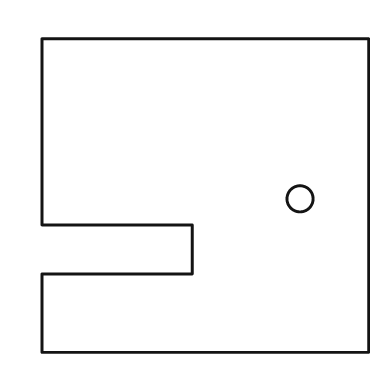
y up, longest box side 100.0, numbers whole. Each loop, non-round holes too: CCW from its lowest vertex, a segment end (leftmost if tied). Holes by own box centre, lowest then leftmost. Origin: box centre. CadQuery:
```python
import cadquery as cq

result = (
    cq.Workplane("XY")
    .moveTo(-50.0, -48.0)
    .lineTo(50.0, -48.0)
    .lineTo(50.0, 48.0)
    .lineTo(-50.0, 48.0)
    .lineTo(-50.0, -9.0)
    .lineTo(-4.0, -9.0)
    .lineTo(-4.0, -24.0)
    .lineTo(-50.0, -24.0)
    .close()
    .moveTo(29.0, -1.0)
    .circle(4.0)
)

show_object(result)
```